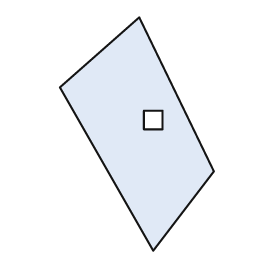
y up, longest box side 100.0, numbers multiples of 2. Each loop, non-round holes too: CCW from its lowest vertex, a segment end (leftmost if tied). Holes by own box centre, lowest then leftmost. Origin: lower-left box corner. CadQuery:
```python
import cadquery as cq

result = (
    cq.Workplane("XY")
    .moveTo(40.0, 0.0)
    .lineTo(66.0, 34.0)
    .lineTo(34.0, 100.0)
    .lineTo(0.0, 70.0)
    .close()
    .moveTo(36.0, 52.0)
    .lineTo(44.0, 52.0)
    .lineTo(44.0, 60.0)
    .lineTo(36.0, 60.0)
    .close()
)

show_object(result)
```